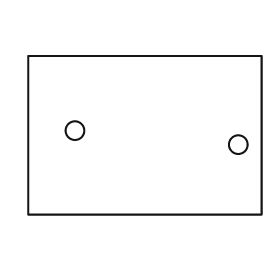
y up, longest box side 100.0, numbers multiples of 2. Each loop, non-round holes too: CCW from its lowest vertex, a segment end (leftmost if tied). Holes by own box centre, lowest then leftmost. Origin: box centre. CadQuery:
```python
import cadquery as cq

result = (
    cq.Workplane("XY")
    .moveTo(-50.0, -34.0)
    .lineTo(50.0, -34.0)
    .lineTo(50.0, 34.0)
    .lineTo(-50.0, 34.0)
    .close()
    .moveTo(40.0, -4.0)
    .circle(4.0)
    .moveTo(-30.0, 2.0)
    .circle(4.0)
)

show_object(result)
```